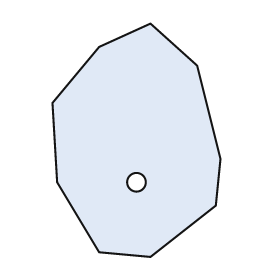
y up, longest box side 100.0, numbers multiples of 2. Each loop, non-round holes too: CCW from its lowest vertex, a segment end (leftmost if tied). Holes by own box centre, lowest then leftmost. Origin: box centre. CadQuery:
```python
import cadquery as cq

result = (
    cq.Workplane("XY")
    .moveTo(6.0, -50.0)
    .lineTo(34.0, -28.0)
    .lineTo(36.0, -8.0)
    .lineTo(26.0, 32.0)
    .lineTo(6.0, 50.0)
    .lineTo(-16.0, 40.0)
    .lineTo(-36.0, 16.0)
    .lineTo(-34.0, -18.0)
    .lineTo(-16.0, -48.0)
    .close()
    .moveTo(0.0, -18.0)
    .circle(4.0)
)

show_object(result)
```